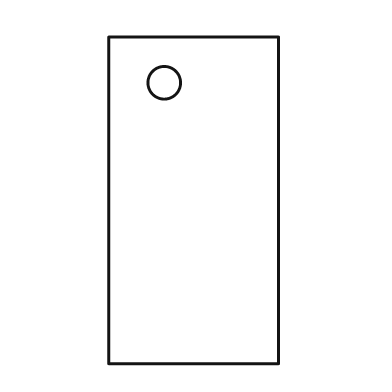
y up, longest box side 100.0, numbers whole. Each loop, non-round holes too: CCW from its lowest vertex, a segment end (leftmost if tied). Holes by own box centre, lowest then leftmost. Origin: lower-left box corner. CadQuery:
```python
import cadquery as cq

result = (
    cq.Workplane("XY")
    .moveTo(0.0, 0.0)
    .lineTo(52.0, 0.0)
    .lineTo(52.0, 100.0)
    .lineTo(0.0, 100.0)
    .close()
    .moveTo(17.0, 86.0)
    .circle(5.0)
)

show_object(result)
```